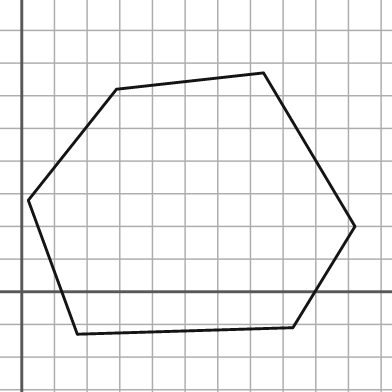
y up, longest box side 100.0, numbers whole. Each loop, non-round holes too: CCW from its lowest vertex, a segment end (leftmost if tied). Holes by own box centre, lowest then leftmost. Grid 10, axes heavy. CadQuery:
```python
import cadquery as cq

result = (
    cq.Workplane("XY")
    .moveTo(17.0, -13.0)
    .lineTo(83.0, -11.0)
    .lineTo(102.0, 20.0)
    .lineTo(74.0, 67.0)
    .lineTo(29.0, 62.0)
    .lineTo(2.0, 28.0)
    .close()
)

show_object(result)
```